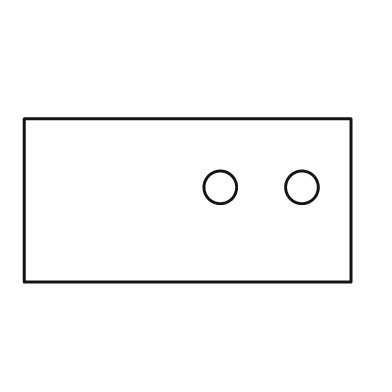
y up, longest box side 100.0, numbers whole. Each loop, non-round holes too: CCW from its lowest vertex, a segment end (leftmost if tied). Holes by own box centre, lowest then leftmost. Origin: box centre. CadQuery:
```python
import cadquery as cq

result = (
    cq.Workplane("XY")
    .moveTo(-50.0, -25.0)
    .lineTo(50.0, -25.0)
    .lineTo(50.0, 25.0)
    .lineTo(-50.0, 25.0)
    .close()
    .moveTo(10.0, 4.0)
    .circle(5.0)
    .moveTo(35.0, 4.0)
    .circle(5.0)
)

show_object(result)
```